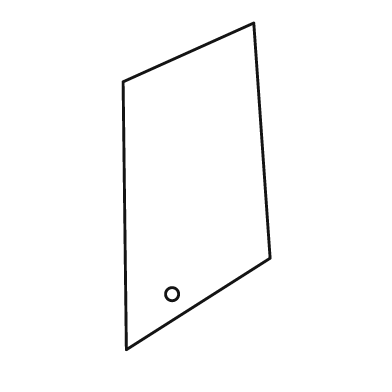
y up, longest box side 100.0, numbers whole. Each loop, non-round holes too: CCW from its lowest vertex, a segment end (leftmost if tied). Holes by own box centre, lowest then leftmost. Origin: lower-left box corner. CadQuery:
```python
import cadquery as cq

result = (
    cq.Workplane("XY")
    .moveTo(1.0, 0.0)
    .lineTo(45.0, 28.0)
    .lineTo(40.0, 100.0)
    .lineTo(0.0, 82.0)
    .close()
    .moveTo(15.0, 17.0)
    .circle(2.0)
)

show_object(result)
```